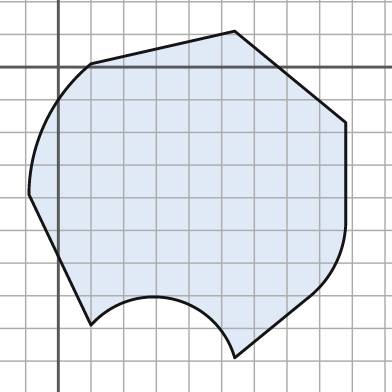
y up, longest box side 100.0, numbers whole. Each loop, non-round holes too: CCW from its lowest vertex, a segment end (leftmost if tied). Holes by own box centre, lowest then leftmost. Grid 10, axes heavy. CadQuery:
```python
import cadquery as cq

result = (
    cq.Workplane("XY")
    .moveTo(54.0, -89.0)
    .lineTo(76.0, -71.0)
    .threePointArc((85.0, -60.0), (88.0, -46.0))
    .lineTo(88.0, -17.0)
    .lineTo(54.0, 11.0)
    .lineTo(10.0, 1.0)
    .threePointArc((-4.0, -17.0), (-9.0, -39.0))
    .lineTo(10.0, -79.0)
    .threePointArc((35.0, -71.0), (54.0, -89.0))
    .close()
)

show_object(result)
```